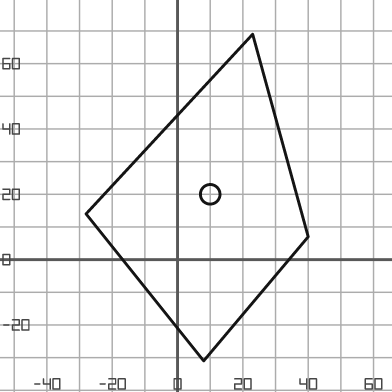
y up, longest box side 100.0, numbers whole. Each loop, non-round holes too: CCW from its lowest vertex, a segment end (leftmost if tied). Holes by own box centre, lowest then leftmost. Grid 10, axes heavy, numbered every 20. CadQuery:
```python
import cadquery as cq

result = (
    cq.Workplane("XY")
    .moveTo(8.0, -31.0)
    .lineTo(40.0, 7.0)
    .lineTo(23.0, 69.0)
    .lineTo(-28.0, 14.0)
    .close()
    .moveTo(10.0, 20.0)
    .circle(3.0)
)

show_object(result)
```